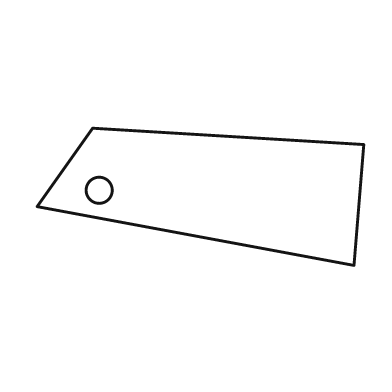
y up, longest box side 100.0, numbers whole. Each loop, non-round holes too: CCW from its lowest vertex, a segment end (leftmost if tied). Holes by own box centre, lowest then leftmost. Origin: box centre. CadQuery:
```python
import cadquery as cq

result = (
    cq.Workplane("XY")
    .moveTo(47.0, -21.0)
    .lineTo(50.0, 16.0)
    .lineTo(-33.0, 21.0)
    .lineTo(-50.0, -3.0)
    .close()
    .moveTo(-31.0, 2.0)
    .circle(4.0)
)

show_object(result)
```